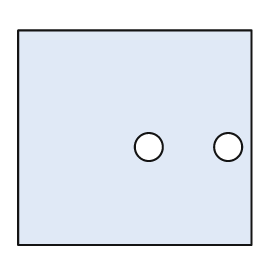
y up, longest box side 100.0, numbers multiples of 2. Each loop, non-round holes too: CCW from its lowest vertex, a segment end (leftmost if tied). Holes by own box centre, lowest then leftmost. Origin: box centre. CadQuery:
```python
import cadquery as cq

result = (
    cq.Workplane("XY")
    .moveTo(-50.0, -46.0)
    .lineTo(50.0, -46.0)
    .lineTo(50.0, 46.0)
    .lineTo(-50.0, 46.0)
    .close()
    .moveTo(6.0, -4.0)
    .circle(6.0)
    .moveTo(40.0, -4.0)
    .circle(6.0)
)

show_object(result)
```